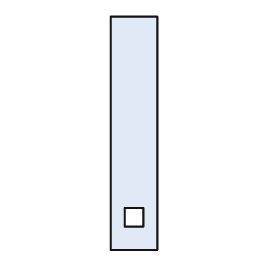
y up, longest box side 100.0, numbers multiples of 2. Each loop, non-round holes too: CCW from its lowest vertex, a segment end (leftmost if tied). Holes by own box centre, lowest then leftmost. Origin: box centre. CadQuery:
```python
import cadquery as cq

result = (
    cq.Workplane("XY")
    .moveTo(-10.0, -50.0)
    .lineTo(10.0, -50.0)
    .lineTo(10.0, 50.0)
    .lineTo(-10.0, 50.0)
    .close()
    .moveTo(-4.0, -40.0)
    .lineTo(4.0, -40.0)
    .lineTo(4.0, -32.0)
    .lineTo(-4.0, -32.0)
    .close()
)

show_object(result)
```